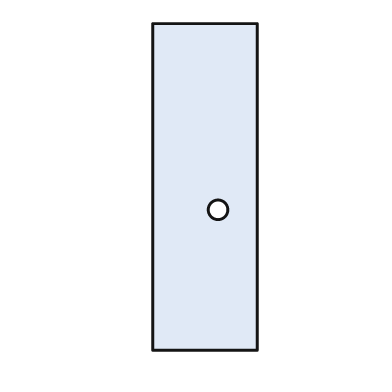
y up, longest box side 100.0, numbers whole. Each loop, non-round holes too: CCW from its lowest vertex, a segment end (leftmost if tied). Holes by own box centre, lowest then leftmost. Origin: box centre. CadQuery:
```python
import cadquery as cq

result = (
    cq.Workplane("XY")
    .moveTo(-16.0, -50.0)
    .lineTo(16.0, -50.0)
    .lineTo(16.0, 50.0)
    .lineTo(-16.0, 50.0)
    .close()
    .moveTo(4.0, -7.0)
    .circle(3.0)
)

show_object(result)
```